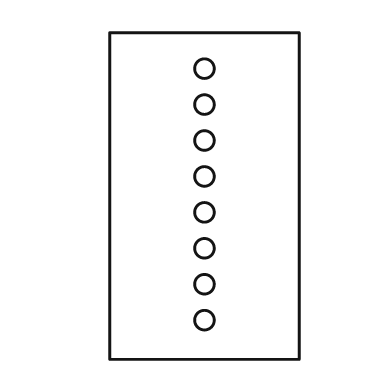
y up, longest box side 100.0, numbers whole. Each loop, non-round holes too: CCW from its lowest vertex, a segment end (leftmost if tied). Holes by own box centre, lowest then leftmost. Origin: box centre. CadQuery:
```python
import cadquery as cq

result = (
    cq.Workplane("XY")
    .moveTo(-29.0, -50.0)
    .lineTo(29.0, -50.0)
    .lineTo(29.0, 50.0)
    .lineTo(-29.0, 50.0)
    .close()
    .moveTo(0.0, -38.0)
    .circle(3.0)
    .moveTo(0.0, -27.0)
    .circle(3.0)
    .moveTo(0.0, -16.0)
    .circle(3.0)
    .moveTo(0.0, -5.0)
    .circle(3.0)
    .moveTo(0.0, 6.0)
    .circle(3.0)
    .moveTo(0.0, 17.0)
    .circle(3.0)
    .moveTo(0.0, 28.0)
    .circle(3.0)
    .moveTo(0.0, 39.0)
    .circle(3.0)
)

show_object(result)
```